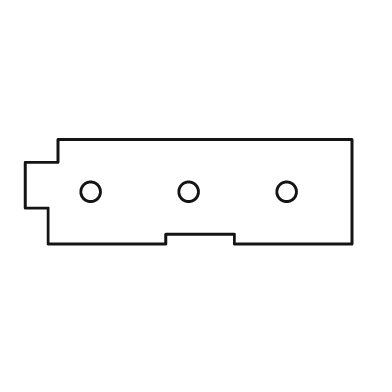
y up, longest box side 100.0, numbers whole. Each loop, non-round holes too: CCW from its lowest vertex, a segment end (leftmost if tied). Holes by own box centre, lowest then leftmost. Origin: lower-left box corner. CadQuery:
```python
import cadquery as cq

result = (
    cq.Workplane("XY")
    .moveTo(7.0, 0.0)
    .lineTo(43.0, 0.0)
    .lineTo(43.0, 3.0)
    .lineTo(64.0, 3.0)
    .lineTo(64.0, 0.0)
    .lineTo(100.0, 0.0)
    .lineTo(100.0, 32.0)
    .lineTo(10.0, 32.0)
    .lineTo(10.0, 25.0)
    .lineTo(0.0, 25.0)
    .lineTo(0.0, 11.0)
    .lineTo(7.0, 11.0)
    .close()
    .moveTo(20.0, 16.0)
    .circle(3.0)
    .moveTo(50.0, 16.0)
    .circle(3.0)
    .moveTo(80.0, 16.0)
    .circle(3.0)
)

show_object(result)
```